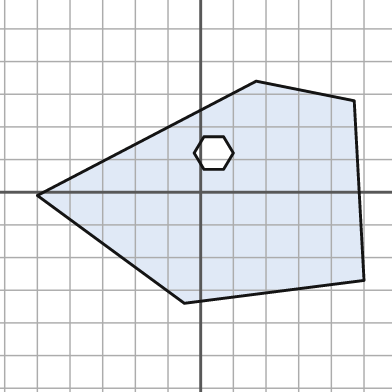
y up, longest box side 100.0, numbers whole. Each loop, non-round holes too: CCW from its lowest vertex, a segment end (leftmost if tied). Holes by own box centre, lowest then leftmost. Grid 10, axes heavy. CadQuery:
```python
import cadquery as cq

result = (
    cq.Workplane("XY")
    .moveTo(-5.0, -34.0)
    .lineTo(50.0, -27.0)
    .lineTo(47.0, 28.0)
    .lineTo(17.0, 34.0)
    .lineTo(-50.0, -1.0)
    .close()
    .moveTo(1.0, 7.0)
    .lineTo(7.0, 7.0)
    .lineTo(10.0, 12.0)
    .lineTo(7.0, 17.0)
    .lineTo(1.0, 17.0)
    .lineTo(-2.0, 12.0)
    .close()
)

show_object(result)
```